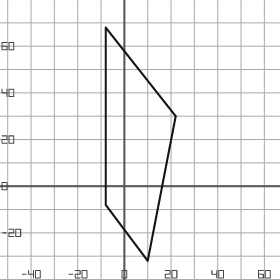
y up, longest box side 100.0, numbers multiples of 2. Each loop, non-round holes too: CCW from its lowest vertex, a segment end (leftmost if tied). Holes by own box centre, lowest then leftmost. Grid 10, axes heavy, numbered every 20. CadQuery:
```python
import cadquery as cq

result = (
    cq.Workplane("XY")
    .moveTo(10.0, -32.0)
    .lineTo(22.0, 30.0)
    .lineTo(-8.0, 68.0)
    .lineTo(-8.0, -8.0)
    .close()
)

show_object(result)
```